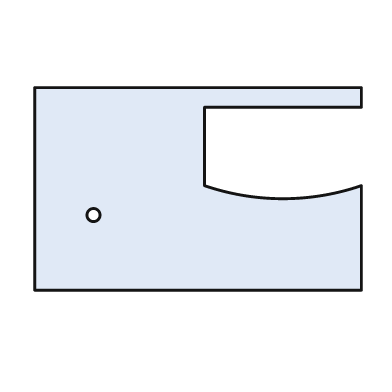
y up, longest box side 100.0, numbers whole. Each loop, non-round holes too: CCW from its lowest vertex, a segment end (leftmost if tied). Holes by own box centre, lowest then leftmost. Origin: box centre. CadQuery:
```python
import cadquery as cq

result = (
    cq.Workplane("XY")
    .moveTo(-50.0, -31.0)
    .lineTo(50.0, -31.0)
    .lineTo(50.0, 1.0)
    .threePointArc((26.0, -3.0), (2.0, 1.0))
    .lineTo(2.0, 25.0)
    .lineTo(50.0, 25.0)
    .lineTo(50.0, 31.0)
    .lineTo(-50.0, 31.0)
    .close()
    .moveTo(-32.0, -8.0)
    .circle(2.0)
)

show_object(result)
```